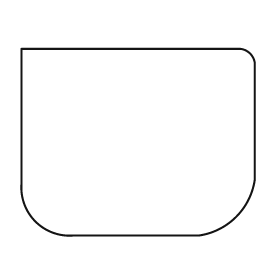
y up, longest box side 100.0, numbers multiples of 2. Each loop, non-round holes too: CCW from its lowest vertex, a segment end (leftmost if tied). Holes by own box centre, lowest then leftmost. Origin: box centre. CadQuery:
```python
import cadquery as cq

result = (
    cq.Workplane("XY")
    .moveTo(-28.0, -40.0)
    .lineTo(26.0, -40.0)
    .threePointArc((42.0, -32.0), (50.0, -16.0))
    .lineTo(50.0, 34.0)
    .threePointArc((48.0, 38.0), (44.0, 40.0))
    .lineTo(-50.0, 40.0)
    .lineTo(-50.0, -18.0)
    .threePointArc((-44.0, -34.0), (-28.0, -40.0))
    .close()
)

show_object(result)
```